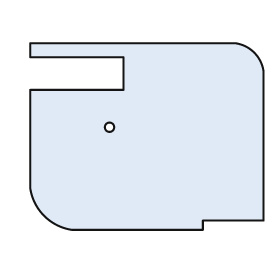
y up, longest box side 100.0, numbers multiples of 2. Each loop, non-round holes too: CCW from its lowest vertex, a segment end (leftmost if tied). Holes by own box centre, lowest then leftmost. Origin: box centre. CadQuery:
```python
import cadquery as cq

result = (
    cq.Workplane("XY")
    .moveTo(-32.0, -40.0)
    .lineTo(24.0, -40.0)
    .lineTo(24.0, -36.0)
    .lineTo(50.0, -36.0)
    .lineTo(50.0, 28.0)
    .threePointArc((46.0, 36.0), (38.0, 40.0))
    .lineTo(-50.0, 40.0)
    .lineTo(-50.0, 34.0)
    .lineTo(-10.0, 34.0)
    .lineTo(-10.0, 20.0)
    .lineTo(-50.0, 20.0)
    .lineTo(-50.0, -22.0)
    .threePointArc((-44.0, -34.0), (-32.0, -40.0))
    .close()
    .moveTo(-16.0, 4.0)
    .circle(2.0)
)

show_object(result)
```